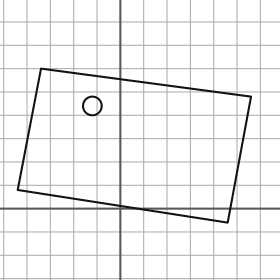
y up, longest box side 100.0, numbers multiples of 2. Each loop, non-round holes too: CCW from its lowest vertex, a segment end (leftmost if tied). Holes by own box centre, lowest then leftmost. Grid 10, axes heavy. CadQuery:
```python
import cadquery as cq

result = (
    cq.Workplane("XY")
    .moveTo(46.0, -6.0)
    .lineTo(56.0, 48.0)
    .lineTo(-34.0, 60.0)
    .lineTo(-44.0, 8.0)
    .close()
    .moveTo(-12.0, 44.0)
    .circle(4.0)
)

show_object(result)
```